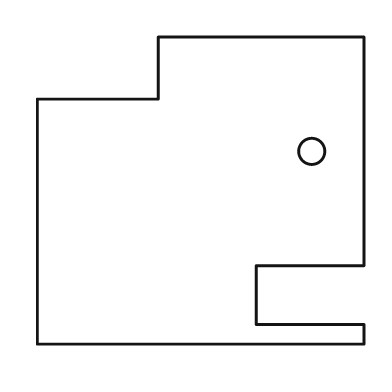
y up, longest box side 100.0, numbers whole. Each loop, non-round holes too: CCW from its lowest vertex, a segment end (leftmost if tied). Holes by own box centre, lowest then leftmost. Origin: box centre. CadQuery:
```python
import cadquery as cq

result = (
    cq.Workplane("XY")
    .moveTo(-50.0, -47.0)
    .lineTo(50.0, -47.0)
    .lineTo(50.0, -41.0)
    .lineTo(17.0, -41.0)
    .lineTo(17.0, -23.0)
    .lineTo(50.0, -23.0)
    .lineTo(50.0, 47.0)
    .lineTo(-13.0, 47.0)
    .lineTo(-13.0, 28.0)
    .lineTo(-50.0, 28.0)
    .close()
    .moveTo(34.0, 12.0)
    .circle(4.0)
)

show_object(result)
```